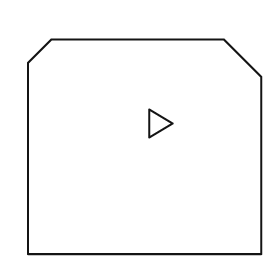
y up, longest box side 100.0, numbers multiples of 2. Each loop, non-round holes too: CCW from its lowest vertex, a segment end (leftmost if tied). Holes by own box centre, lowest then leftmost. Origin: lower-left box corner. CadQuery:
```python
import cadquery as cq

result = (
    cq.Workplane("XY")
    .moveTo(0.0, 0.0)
    .lineTo(100.0, 0.0)
    .lineTo(100.0, 76.0)
    .lineTo(84.0, 92.0)
    .lineTo(10.0, 92.0)
    .lineTo(0.0, 82.0)
    .close()
    .moveTo(52.0, 50.0)
    .lineTo(62.0, 56.0)
    .lineTo(52.0, 62.0)
    .close()
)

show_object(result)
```